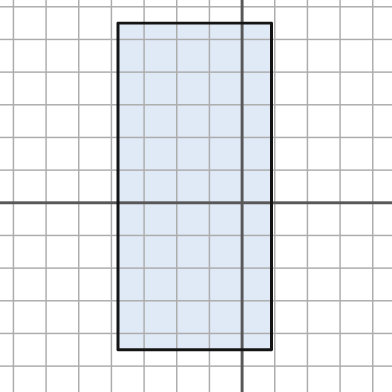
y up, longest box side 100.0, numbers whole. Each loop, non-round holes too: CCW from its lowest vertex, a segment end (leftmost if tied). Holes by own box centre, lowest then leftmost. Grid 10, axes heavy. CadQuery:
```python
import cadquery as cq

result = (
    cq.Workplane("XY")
    .moveTo(-38.0, -45.0)
    .lineTo(9.0, -45.0)
    .lineTo(9.0, 55.0)
    .lineTo(-38.0, 55.0)
    .close()
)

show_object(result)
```